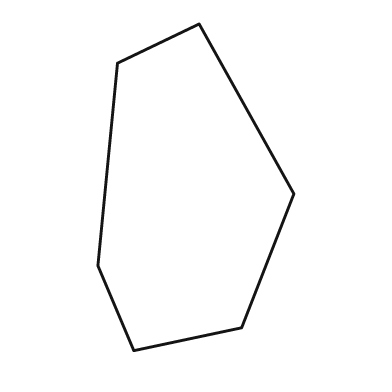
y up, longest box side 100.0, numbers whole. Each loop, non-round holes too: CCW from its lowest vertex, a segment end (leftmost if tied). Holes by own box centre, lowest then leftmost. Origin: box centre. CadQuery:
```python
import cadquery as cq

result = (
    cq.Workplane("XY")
    .moveTo(-19.0, -50.0)
    .lineTo(14.0, -43.0)
    .lineTo(30.0, -2.0)
    .lineTo(1.0, 50.0)
    .lineTo(-24.0, 38.0)
    .lineTo(-30.0, -24.0)
    .close()
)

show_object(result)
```